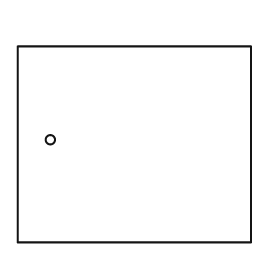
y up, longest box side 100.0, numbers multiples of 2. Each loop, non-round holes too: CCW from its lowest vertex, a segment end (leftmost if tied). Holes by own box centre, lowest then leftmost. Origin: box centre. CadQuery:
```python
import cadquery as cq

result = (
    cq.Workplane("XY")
    .moveTo(-50.0, -42.0)
    .lineTo(50.0, -42.0)
    .lineTo(50.0, 42.0)
    .lineTo(-50.0, 42.0)
    .close()
    .moveTo(-36.0, 2.0)
    .circle(2.0)
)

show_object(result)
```